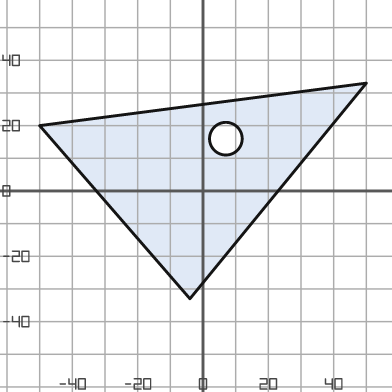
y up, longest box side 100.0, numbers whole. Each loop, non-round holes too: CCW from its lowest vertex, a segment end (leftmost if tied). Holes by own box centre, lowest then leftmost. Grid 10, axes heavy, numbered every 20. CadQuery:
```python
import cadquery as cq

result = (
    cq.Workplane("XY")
    .moveTo(-4.0, -33.0)
    .lineTo(50.0, 33.0)
    .lineTo(-50.0, 20.0)
    .close()
    .moveTo(7.0, 16.0)
    .circle(5.0)
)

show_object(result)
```